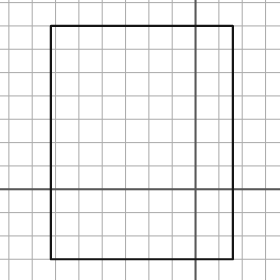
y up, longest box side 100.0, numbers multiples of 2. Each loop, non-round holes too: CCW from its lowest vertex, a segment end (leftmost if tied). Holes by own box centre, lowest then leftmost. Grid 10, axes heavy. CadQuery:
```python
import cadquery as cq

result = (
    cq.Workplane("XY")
    .moveTo(-62.0, -30.0)
    .lineTo(16.0, -30.0)
    .lineTo(16.0, 70.0)
    .lineTo(-62.0, 70.0)
    .close()
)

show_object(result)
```